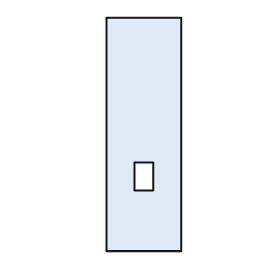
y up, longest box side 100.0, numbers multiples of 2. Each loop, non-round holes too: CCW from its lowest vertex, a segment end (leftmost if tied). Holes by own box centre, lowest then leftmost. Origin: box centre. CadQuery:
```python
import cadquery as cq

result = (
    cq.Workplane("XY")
    .moveTo(-16.0, -50.0)
    .lineTo(16.0, -50.0)
    .lineTo(16.0, 50.0)
    .lineTo(-16.0, 50.0)
    .close()
    .moveTo(-4.0, -24.0)
    .lineTo(4.0, -24.0)
    .lineTo(4.0, -12.0)
    .lineTo(-4.0, -12.0)
    .close()
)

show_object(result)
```